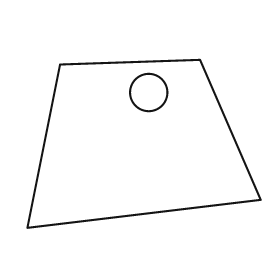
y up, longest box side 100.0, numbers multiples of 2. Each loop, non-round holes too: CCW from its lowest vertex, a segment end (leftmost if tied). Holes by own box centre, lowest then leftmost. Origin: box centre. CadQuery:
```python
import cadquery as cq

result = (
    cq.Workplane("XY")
    .moveTo(-50.0, -36.0)
    .lineTo(50.0, -24.0)
    .lineTo(24.0, 36.0)
    .lineTo(-36.0, 34.0)
    .close()
    .moveTo(2.0, 22.0)
    .circle(8.0)
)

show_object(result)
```